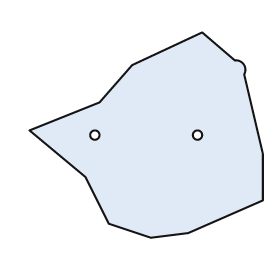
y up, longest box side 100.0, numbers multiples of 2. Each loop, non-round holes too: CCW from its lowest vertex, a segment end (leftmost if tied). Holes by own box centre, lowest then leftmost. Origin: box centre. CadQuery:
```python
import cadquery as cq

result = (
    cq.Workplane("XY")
    .moveTo(2.0, -44.0)
    .lineTo(18.0, -42.0)
    .lineTo(50.0, -28.0)
    .lineTo(50.0, -8.0)
    .lineTo(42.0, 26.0)
    .threePointArc((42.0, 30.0), (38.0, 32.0))
    .lineTo(24.0, 44.0)
    .lineTo(-6.0, 30.0)
    .lineTo(-20.0, 14.0)
    .lineTo(-50.0, 2.0)
    .lineTo(-26.0, -18.0)
    .lineTo(-16.0, -38.0)
    .close()
    .moveTo(-22.0, 0.0)
    .circle(2.0)
    .moveTo(22.0, 0.0)
    .circle(2.0)
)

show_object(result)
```